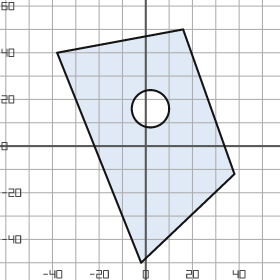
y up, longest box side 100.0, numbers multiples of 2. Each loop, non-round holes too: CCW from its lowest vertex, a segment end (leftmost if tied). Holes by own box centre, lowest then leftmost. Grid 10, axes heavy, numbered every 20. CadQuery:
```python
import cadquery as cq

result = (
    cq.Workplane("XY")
    .moveTo(-2.0, -50.0)
    .lineTo(38.0, -12.0)
    .lineTo(16.0, 50.0)
    .lineTo(-38.0, 40.0)
    .close()
    .moveTo(2.0, 16.0)
    .circle(8.0)
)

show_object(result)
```